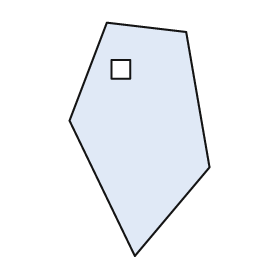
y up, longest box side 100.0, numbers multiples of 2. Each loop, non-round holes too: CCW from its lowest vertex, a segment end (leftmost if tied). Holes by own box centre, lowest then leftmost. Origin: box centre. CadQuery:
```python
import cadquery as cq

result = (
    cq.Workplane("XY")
    .moveTo(-2.0, -50.0)
    .lineTo(30.0, -12.0)
    .lineTo(20.0, 46.0)
    .lineTo(-14.0, 50.0)
    .lineTo(-30.0, 8.0)
    .close()
    .moveTo(-12.0, 26.0)
    .lineTo(-4.0, 26.0)
    .lineTo(-4.0, 34.0)
    .lineTo(-12.0, 34.0)
    .close()
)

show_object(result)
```